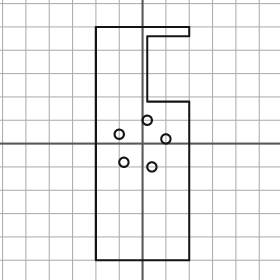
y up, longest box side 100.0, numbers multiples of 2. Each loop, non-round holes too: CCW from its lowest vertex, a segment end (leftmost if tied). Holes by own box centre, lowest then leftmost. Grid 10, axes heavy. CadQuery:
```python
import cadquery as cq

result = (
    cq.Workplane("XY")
    .moveTo(-20.0, -50.0)
    .lineTo(20.0, -50.0)
    .lineTo(20.0, 18.0)
    .lineTo(2.0, 18.0)
    .lineTo(2.0, 46.0)
    .lineTo(20.0, 46.0)
    .lineTo(20.0, 50.0)
    .lineTo(-20.0, 50.0)
    .close()
    .moveTo(4.0, -10.0)
    .circle(2.0)
    .moveTo(-8.0, -8.0)
    .circle(2.0)
    .moveTo(10.0, 2.0)
    .circle(2.0)
    .moveTo(-10.0, 4.0)
    .circle(2.0)
    .moveTo(2.0, 10.0)
    .circle(2.0)
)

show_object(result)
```